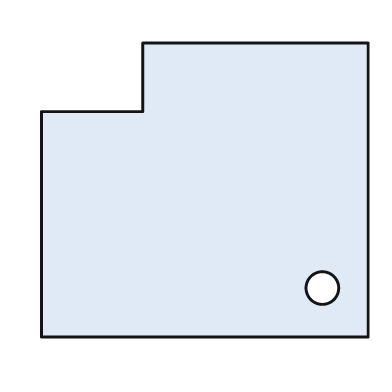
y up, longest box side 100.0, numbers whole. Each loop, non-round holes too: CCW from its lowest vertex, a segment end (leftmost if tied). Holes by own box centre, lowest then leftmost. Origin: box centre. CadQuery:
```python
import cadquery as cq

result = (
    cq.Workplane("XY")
    .moveTo(-50.0, -45.0)
    .lineTo(50.0, -45.0)
    .lineTo(50.0, 45.0)
    .lineTo(-19.0, 45.0)
    .lineTo(-19.0, 24.0)
    .lineTo(-50.0, 24.0)
    .close()
    .moveTo(36.0, -30.0)
    .circle(5.0)
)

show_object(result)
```